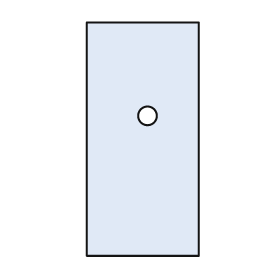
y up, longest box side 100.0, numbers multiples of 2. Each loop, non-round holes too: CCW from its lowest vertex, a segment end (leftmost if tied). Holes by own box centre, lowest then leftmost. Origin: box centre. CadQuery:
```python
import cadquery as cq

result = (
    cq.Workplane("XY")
    .moveTo(-24.0, -50.0)
    .lineTo(24.0, -50.0)
    .lineTo(24.0, 50.0)
    .lineTo(-24.0, 50.0)
    .close()
    .moveTo(2.0, 10.0)
    .circle(4.0)
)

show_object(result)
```